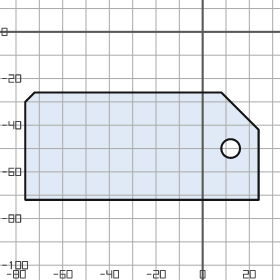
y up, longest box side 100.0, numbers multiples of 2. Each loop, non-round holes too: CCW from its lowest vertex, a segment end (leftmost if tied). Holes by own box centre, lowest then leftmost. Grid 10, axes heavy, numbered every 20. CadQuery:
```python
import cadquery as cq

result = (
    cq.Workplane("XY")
    .moveTo(-76.0, -72.0)
    .lineTo(24.0, -72.0)
    .lineTo(24.0, -42.0)
    .lineTo(8.0, -26.0)
    .lineTo(-72.0, -26.0)
    .lineTo(-76.0, -30.0)
    .close()
    .moveTo(12.0, -50.0)
    .circle(4.0)
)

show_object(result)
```